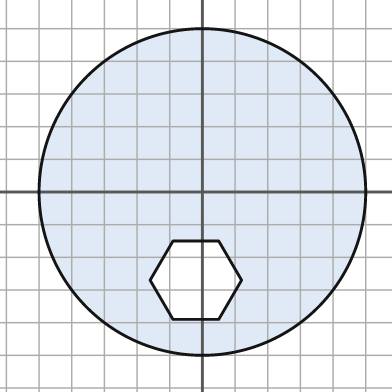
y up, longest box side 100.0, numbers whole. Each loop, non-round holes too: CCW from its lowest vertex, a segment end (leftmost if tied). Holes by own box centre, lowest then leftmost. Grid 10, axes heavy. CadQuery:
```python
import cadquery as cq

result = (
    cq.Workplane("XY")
    .moveTo(0.0, 0.0)
    .circle(50.0)
    .moveTo(-9.0, -39.0)
    .lineTo(5.0, -39.0)
    .lineTo(12.0, -27.0)
    .lineTo(5.0, -15.0)
    .lineTo(-9.0, -15.0)
    .lineTo(-16.0, -27.0)
    .close()
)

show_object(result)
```